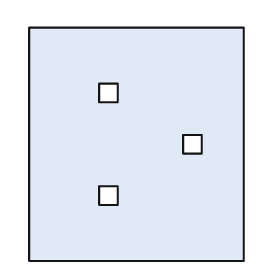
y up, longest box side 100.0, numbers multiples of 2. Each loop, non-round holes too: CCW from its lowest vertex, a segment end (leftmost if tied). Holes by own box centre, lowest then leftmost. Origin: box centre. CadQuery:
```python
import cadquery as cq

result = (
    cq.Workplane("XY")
    .moveTo(-46.0, -50.0)
    .lineTo(46.0, -50.0)
    .lineTo(46.0, 50.0)
    .lineTo(-46.0, 50.0)
    .close()
    .moveTo(-16.0, -26.0)
    .lineTo(-8.0, -26.0)
    .lineTo(-8.0, -18.0)
    .lineTo(-16.0, -18.0)
    .close()
    .moveTo(20.0, -4.0)
    .lineTo(28.0, -4.0)
    .lineTo(28.0, 4.0)
    .lineTo(20.0, 4.0)
    .close()
    .moveTo(-16.0, 18.0)
    .lineTo(-8.0, 18.0)
    .lineTo(-8.0, 26.0)
    .lineTo(-16.0, 26.0)
    .close()
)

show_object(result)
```